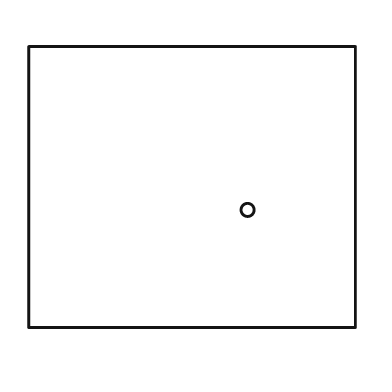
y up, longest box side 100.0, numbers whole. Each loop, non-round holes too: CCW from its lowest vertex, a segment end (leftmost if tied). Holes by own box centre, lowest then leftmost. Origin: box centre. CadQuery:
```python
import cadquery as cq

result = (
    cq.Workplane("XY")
    .moveTo(-50.0, -43.0)
    .lineTo(50.0, -43.0)
    .lineTo(50.0, 43.0)
    .lineTo(-50.0, 43.0)
    .close()
    .moveTo(17.0, -7.0)
    .circle(2.0)
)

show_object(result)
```